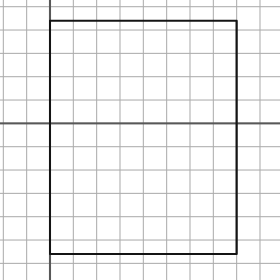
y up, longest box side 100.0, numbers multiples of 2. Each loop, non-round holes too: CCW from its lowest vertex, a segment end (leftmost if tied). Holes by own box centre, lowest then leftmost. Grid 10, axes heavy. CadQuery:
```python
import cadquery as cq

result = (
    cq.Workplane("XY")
    .moveTo(0.0, -56.0)
    .lineTo(80.0, -56.0)
    .lineTo(80.0, 44.0)
    .lineTo(0.0, 44.0)
    .close()
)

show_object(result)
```